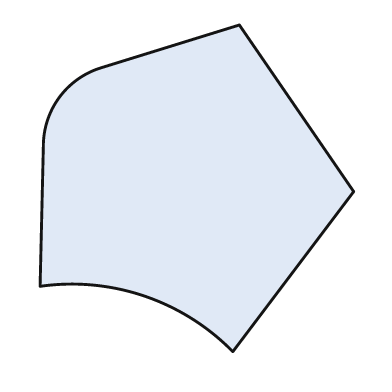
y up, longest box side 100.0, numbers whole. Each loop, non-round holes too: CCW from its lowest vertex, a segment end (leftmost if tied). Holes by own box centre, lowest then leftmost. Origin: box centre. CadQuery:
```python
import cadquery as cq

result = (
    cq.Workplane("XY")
    .moveTo(11.0, -50.0)
    .lineTo(48.0, -1.0)
    .lineTo(13.0, 50.0)
    .lineTo(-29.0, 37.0)
    .threePointArc((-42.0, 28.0), (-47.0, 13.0))
    .lineTo(-48.0, -30.0)
    .threePointArc((-16.0, -33.0), (11.0, -50.0))
    .close()
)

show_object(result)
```